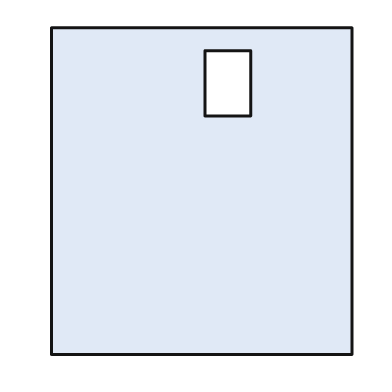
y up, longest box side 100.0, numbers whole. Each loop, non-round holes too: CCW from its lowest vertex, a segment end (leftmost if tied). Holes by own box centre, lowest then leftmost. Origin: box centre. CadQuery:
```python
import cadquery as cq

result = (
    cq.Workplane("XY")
    .moveTo(-46.0, -50.0)
    .lineTo(46.0, -50.0)
    .lineTo(46.0, 50.0)
    .lineTo(-46.0, 50.0)
    .close()
    .moveTo(1.0, 23.0)
    .lineTo(15.0, 23.0)
    .lineTo(15.0, 43.0)
    .lineTo(1.0, 43.0)
    .close()
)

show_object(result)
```